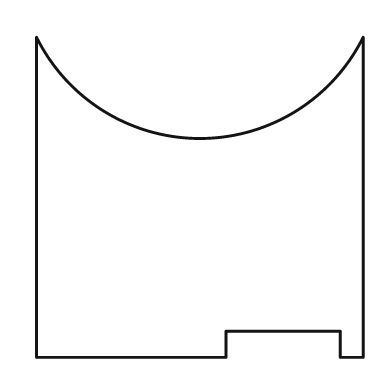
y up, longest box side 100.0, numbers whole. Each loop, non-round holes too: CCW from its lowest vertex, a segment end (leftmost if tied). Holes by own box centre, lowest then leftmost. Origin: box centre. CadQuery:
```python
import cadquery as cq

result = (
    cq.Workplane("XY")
    .moveTo(-50.0, -49.0)
    .lineTo(8.0, -49.0)
    .lineTo(8.0, -41.0)
    .lineTo(43.0, -41.0)
    .lineTo(43.0, -49.0)
    .lineTo(50.0, -49.0)
    .lineTo(50.0, 49.0)
    .threePointArc((0.0, 18.0), (-50.0, 49.0))
    .close()
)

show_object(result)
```